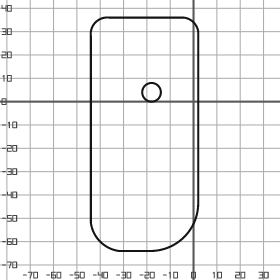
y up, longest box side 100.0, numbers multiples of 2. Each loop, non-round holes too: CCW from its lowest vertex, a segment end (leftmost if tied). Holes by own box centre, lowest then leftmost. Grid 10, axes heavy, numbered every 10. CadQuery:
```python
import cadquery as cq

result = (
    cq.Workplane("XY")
    .moveTo(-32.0, -64.0)
    .lineTo(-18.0, -64.0)
    .threePointArc((-4.0, -58.0), (2.0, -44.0))
    .lineTo(2.0, 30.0)
    .threePointArc((0.0, 34.0), (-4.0, 36.0))
    .lineTo(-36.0, 36.0)
    .threePointArc((-42.0, 34.0), (-44.0, 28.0))
    .lineTo(-44.0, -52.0)
    .threePointArc((-40.0, -60.0), (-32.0, -64.0))
    .close()
    .moveTo(-18.0, 4.0)
    .circle(4.0)
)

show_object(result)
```